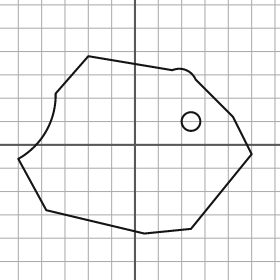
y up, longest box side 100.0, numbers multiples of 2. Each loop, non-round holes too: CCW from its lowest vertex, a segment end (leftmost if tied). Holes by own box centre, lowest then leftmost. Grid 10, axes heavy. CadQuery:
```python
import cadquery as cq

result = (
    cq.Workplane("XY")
    .moveTo(4.0, -38.0)
    .lineTo(24.0, -36.0)
    .lineTo(50.0, -4.0)
    .lineTo(42.0, 12.0)
    .lineTo(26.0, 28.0)
    .threePointArc((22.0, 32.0), (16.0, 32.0))
    .lineTo(-20.0, 38.0)
    .lineTo(-34.0, 22.0)
    .threePointArc((-38.0, 6.0), (-50.0, -6.0))
    .lineTo(-38.0, -28.0)
    .close()
    .moveTo(24.0, 10.0)
    .circle(4.0)
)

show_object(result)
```